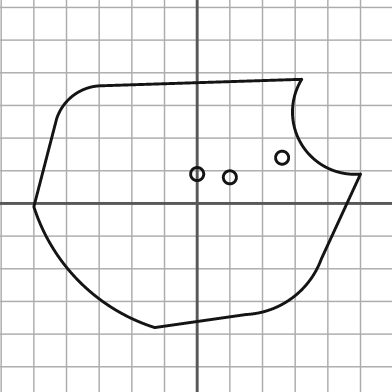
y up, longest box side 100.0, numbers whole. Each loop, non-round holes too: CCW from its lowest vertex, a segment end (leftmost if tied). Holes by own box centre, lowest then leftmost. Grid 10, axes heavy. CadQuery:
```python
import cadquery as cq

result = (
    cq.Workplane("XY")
    .moveTo(-13.0, -38.0)
    .lineTo(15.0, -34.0)
    .threePointArc((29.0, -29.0), (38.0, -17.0))
    .lineTo(50.0, 9.0)
    .threePointArc((32.0, 18.0), (32.0, 38.0))
    .lineTo(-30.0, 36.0)
    .threePointArc((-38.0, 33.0), (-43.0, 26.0))
    .lineTo(-50.0, -1.0)
    .threePointArc((-36.0, -24.0), (-13.0, -38.0))
    .close()
    .moveTo(10.0, 8.0)
    .circle(2.0)
    .moveTo(0.0, 9.0)
    .circle(2.0)
    .moveTo(26.0, 14.0)
    .circle(2.0)
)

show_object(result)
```